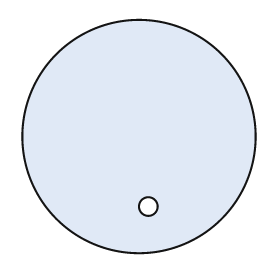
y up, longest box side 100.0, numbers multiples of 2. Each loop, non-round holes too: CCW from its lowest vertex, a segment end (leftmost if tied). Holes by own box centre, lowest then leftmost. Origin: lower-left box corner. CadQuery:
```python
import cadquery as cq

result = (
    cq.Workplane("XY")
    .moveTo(50.0, 50.0)
    .circle(50.0)
    .moveTo(54.0, 20.0)
    .circle(4.0)
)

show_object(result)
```